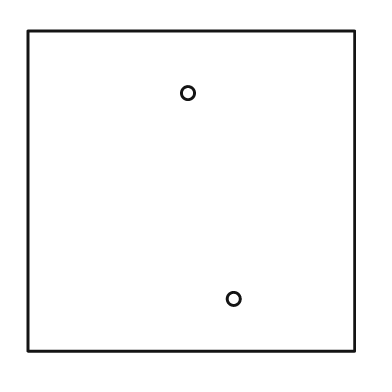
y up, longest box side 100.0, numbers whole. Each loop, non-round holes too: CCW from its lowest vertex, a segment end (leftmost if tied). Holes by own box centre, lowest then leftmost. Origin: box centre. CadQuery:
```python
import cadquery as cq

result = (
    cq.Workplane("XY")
    .moveTo(-50.0, -49.0)
    .lineTo(50.0, -49.0)
    .lineTo(50.0, 49.0)
    .lineTo(-50.0, 49.0)
    .close()
    .moveTo(13.0, -33.0)
    .circle(2.0)
    .moveTo(-1.0, 30.0)
    .circle(2.0)
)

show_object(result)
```